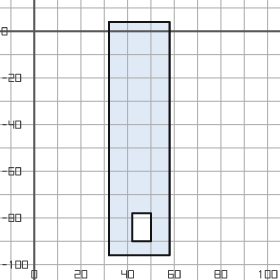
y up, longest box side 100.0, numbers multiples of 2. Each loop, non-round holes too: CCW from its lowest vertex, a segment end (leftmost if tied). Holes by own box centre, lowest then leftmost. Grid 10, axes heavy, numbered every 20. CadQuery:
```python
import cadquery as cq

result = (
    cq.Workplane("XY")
    .moveTo(32.0, -96.0)
    .lineTo(58.0, -96.0)
    .lineTo(58.0, 4.0)
    .lineTo(32.0, 4.0)
    .close()
    .moveTo(42.0, -90.0)
    .lineTo(50.0, -90.0)
    .lineTo(50.0, -78.0)
    .lineTo(42.0, -78.0)
    .close()
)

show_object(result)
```